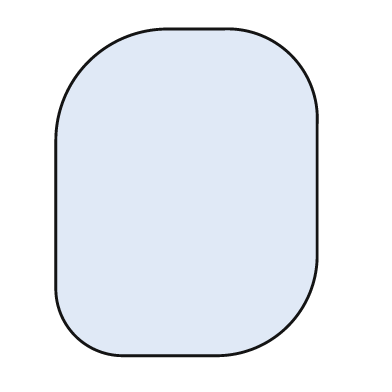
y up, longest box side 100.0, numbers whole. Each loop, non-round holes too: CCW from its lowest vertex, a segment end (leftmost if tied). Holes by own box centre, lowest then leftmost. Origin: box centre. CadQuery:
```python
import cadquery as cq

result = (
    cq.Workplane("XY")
    .moveTo(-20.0, -50.0)
    .lineTo(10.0, -50.0)
    .threePointArc((31.0, -41.0), (40.0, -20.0))
    .lineTo(40.0, 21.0)
    .threePointArc((32.0, 42.0), (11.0, 50.0))
    .lineTo(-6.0, 50.0)
    .threePointArc((-30.0, 40.0), (-40.0, 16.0))
    .lineTo(-40.0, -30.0)
    .threePointArc((-34.0, -44.0), (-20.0, -50.0))
    .close()
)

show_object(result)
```